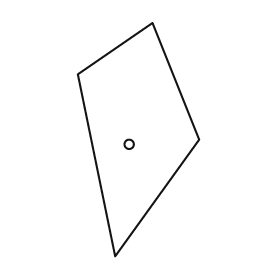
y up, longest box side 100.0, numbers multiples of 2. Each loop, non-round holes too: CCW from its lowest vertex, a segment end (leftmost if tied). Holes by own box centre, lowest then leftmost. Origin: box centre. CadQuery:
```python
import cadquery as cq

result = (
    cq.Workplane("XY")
    .moveTo(-10.0, -50.0)
    .lineTo(26.0, 0.0)
    .lineTo(6.0, 50.0)
    .lineTo(-26.0, 28.0)
    .close()
    .moveTo(-4.0, -2.0)
    .circle(2.0)
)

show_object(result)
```